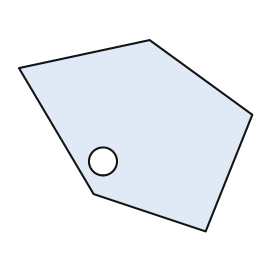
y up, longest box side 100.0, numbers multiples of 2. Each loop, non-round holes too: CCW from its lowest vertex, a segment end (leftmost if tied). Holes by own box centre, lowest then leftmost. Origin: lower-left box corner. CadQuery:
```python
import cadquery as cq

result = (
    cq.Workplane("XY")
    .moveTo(80.0, 0.0)
    .lineTo(100.0, 50.0)
    .lineTo(56.0, 82.0)
    .lineTo(0.0, 70.0)
    .lineTo(32.0, 16.0)
    .close()
    .moveTo(36.0, 30.0)
    .circle(6.0)
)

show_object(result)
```